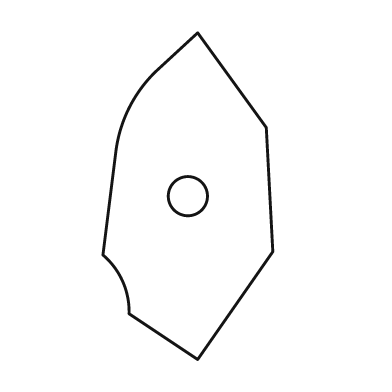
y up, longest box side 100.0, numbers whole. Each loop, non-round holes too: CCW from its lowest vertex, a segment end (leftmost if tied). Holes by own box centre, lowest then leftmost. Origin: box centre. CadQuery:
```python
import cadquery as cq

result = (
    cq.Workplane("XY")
    .moveTo(3.0, -50.0)
    .lineTo(26.0, -17.0)
    .lineTo(24.0, 21.0)
    .lineTo(3.0, 50.0)
    .lineTo(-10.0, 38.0)
    .threePointArc((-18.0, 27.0), (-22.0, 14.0))
    .lineTo(-26.0, -18.0)
    .threePointArc((-20.0, -26.0), (-18.0, -36.0))
    .close()
    .moveTo(0.0, 0.0)
    .circle(6.0)
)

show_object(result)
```